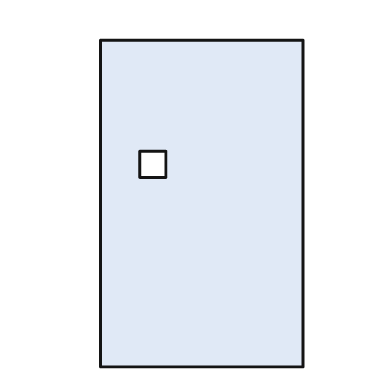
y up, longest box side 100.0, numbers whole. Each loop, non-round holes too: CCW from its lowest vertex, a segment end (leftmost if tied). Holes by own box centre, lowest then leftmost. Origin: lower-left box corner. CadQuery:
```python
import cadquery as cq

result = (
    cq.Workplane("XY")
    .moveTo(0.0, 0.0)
    .lineTo(62.0, 0.0)
    .lineTo(62.0, 100.0)
    .lineTo(0.0, 100.0)
    .close()
    .moveTo(12.0, 58.0)
    .lineTo(20.0, 58.0)
    .lineTo(20.0, 66.0)
    .lineTo(12.0, 66.0)
    .close()
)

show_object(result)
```